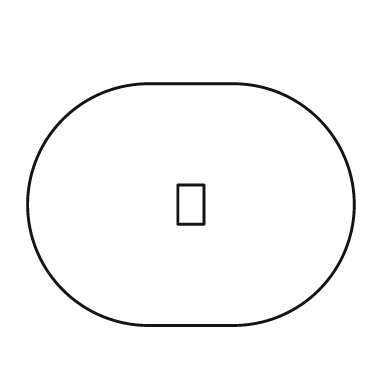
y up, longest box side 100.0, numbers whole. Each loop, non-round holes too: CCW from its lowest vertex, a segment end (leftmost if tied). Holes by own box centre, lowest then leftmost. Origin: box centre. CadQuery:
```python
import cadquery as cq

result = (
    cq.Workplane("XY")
    .moveTo(-13.0, -37.0)
    .lineTo(13.0, -37.0)
    .threePointArc((50.0, 0.0), (13.0, 37.0))
    .lineTo(-13.0, 37.0)
    .threePointArc((-50.0, 0.0), (-13.0, -37.0))
    .close()
    .moveTo(-4.0, -6.0)
    .lineTo(4.0, -6.0)
    .lineTo(4.0, 6.0)
    .lineTo(-4.0, 6.0)
    .close()
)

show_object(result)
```